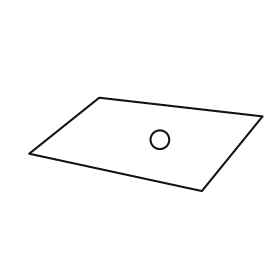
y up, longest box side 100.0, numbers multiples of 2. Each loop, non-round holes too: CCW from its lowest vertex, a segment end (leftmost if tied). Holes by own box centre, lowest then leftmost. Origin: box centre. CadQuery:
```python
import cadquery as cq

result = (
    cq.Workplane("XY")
    .moveTo(24.0, -20.0)
    .lineTo(50.0, 12.0)
    .lineTo(-20.0, 20.0)
    .lineTo(-50.0, -4.0)
    .close()
    .moveTo(6.0, 2.0)
    .circle(4.0)
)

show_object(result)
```